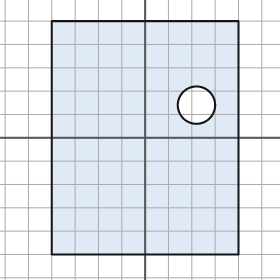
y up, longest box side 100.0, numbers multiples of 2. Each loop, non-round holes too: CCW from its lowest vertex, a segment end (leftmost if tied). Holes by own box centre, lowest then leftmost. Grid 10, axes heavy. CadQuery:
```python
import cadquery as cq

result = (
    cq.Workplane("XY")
    .moveTo(-40.0, -50.0)
    .lineTo(40.0, -50.0)
    .lineTo(40.0, 50.0)
    .lineTo(-40.0, 50.0)
    .close()
    .moveTo(22.0, 14.0)
    .circle(8.0)
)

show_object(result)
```